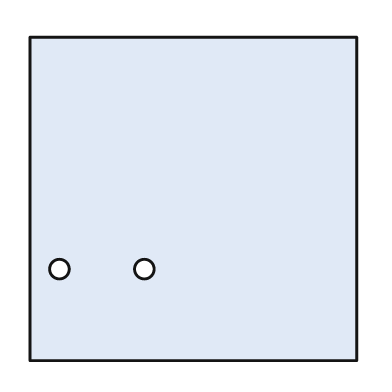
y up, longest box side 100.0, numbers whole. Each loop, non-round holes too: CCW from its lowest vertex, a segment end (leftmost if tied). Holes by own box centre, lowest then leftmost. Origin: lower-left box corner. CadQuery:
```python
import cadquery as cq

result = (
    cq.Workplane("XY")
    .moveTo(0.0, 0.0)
    .lineTo(100.0, 0.0)
    .lineTo(100.0, 99.0)
    .lineTo(0.0, 99.0)
    .close()
    .moveTo(9.0, 28.0)
    .circle(3.0)
    .moveTo(35.0, 28.0)
    .circle(3.0)
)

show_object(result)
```